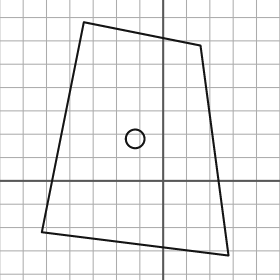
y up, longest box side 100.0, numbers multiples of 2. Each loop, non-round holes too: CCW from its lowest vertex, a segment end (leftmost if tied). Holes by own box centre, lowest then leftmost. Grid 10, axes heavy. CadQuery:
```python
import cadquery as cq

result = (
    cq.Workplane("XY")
    .moveTo(28.0, -32.0)
    .lineTo(16.0, 58.0)
    .lineTo(-34.0, 68.0)
    .lineTo(-52.0, -22.0)
    .close()
    .moveTo(-12.0, 18.0)
    .circle(4.0)
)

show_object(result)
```